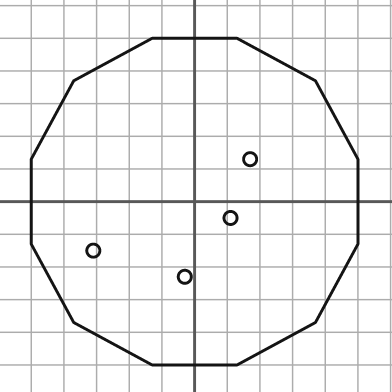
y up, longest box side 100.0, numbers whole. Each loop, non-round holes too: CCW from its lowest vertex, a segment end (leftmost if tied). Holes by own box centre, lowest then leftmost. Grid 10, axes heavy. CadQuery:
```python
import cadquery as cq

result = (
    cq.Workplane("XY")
    .moveTo(-13.0, -50.0)
    .lineTo(13.0, -50.0)
    .lineTo(37.0, -37.0)
    .lineTo(50.0, -13.0)
    .lineTo(50.0, 13.0)
    .lineTo(37.0, 37.0)
    .lineTo(13.0, 50.0)
    .lineTo(-13.0, 50.0)
    .lineTo(-37.0, 37.0)
    .lineTo(-50.0, 13.0)
    .lineTo(-50.0, -13.0)
    .lineTo(-37.0, -37.0)
    .close()
    .moveTo(-3.0, -23.0)
    .circle(2.0)
    .moveTo(-31.0, -15.0)
    .circle(2.0)
    .moveTo(11.0, -5.0)
    .circle(2.0)
    .moveTo(17.0, 13.0)
    .circle(2.0)
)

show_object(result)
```